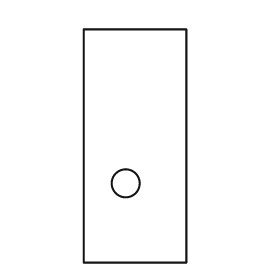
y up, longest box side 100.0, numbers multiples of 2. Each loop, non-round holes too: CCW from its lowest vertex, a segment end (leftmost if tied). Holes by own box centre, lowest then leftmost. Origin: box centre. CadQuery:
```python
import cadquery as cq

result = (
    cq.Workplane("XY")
    .moveTo(-22.0, -50.0)
    .lineTo(22.0, -50.0)
    .lineTo(22.0, 50.0)
    .lineTo(-22.0, 50.0)
    .close()
    .moveTo(-4.0, -16.0)
    .circle(6.0)
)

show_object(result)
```